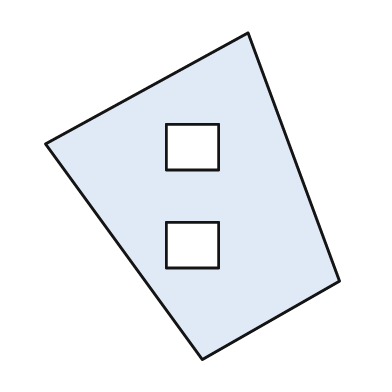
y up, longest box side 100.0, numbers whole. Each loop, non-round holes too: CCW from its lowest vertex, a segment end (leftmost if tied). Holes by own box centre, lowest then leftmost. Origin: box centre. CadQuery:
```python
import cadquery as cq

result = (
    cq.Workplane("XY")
    .moveTo(3.0, -50.0)
    .lineTo(45.0, -26.0)
    .lineTo(17.0, 50.0)
    .lineTo(-45.0, 16.0)
    .close()
    .moveTo(-8.0, -22.0)
    .lineTo(8.0, -22.0)
    .lineTo(8.0, -8.0)
    .lineTo(-8.0, -8.0)
    .close()
    .moveTo(-8.0, 8.0)
    .lineTo(8.0, 8.0)
    .lineTo(8.0, 22.0)
    .lineTo(-8.0, 22.0)
    .close()
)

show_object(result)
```